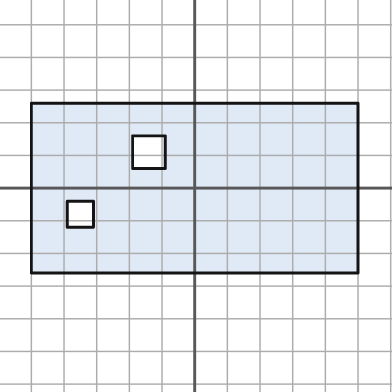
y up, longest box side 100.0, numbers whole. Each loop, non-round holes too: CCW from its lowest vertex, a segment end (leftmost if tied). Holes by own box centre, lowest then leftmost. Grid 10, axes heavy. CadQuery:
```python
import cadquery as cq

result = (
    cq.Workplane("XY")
    .moveTo(-50.0, -26.0)
    .lineTo(50.0, -26.0)
    .lineTo(50.0, 26.0)
    .lineTo(-50.0, 26.0)
    .close()
    .moveTo(-39.0, -12.0)
    .lineTo(-31.0, -12.0)
    .lineTo(-31.0, -4.0)
    .lineTo(-39.0, -4.0)
    .close()
    .moveTo(-19.0, 6.0)
    .lineTo(-9.0, 6.0)
    .lineTo(-9.0, 16.0)
    .lineTo(-19.0, 16.0)
    .close()
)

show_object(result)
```